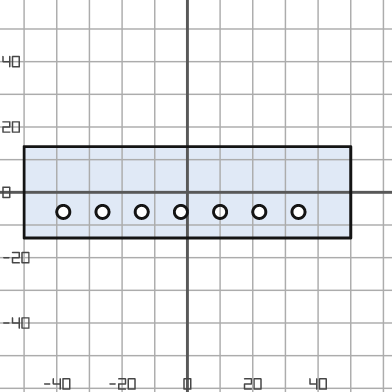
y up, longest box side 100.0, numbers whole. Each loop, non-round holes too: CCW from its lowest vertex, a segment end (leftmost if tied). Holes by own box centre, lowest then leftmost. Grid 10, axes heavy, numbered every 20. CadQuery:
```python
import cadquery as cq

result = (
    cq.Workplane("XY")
    .moveTo(-50.0, -14.0)
    .lineTo(50.0, -14.0)
    .lineTo(50.0, 14.0)
    .lineTo(-50.0, 14.0)
    .close()
    .moveTo(-38.0, -6.0)
    .circle(2.0)
    .moveTo(-26.0, -6.0)
    .circle(2.0)
    .moveTo(-14.0, -6.0)
    .circle(2.0)
    .moveTo(-2.0, -6.0)
    .circle(2.0)
    .moveTo(10.0, -6.0)
    .circle(2.0)
    .moveTo(22.0, -6.0)
    .circle(2.0)
    .moveTo(34.0, -6.0)
    .circle(2.0)
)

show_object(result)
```